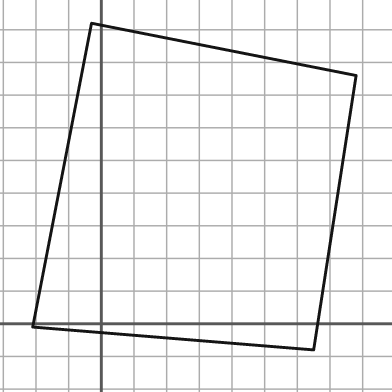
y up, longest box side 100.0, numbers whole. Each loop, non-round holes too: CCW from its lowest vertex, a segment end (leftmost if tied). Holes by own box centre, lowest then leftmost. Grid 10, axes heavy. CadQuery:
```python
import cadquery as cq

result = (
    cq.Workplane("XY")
    .moveTo(65.0, -8.0)
    .lineTo(78.0, 76.0)
    .lineTo(-3.0, 92.0)
    .lineTo(-21.0, -1.0)
    .close()
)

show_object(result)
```